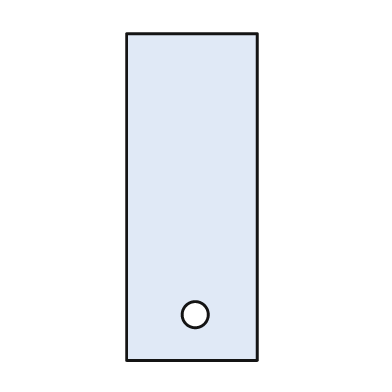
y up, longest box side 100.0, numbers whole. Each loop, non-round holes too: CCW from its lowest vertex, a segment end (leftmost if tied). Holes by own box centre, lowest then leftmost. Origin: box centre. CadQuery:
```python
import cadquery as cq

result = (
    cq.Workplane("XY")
    .moveTo(-20.0, -50.0)
    .lineTo(20.0, -50.0)
    .lineTo(20.0, 50.0)
    .lineTo(-20.0, 50.0)
    .close()
    .moveTo(1.0, -36.0)
    .circle(4.0)
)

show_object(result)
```